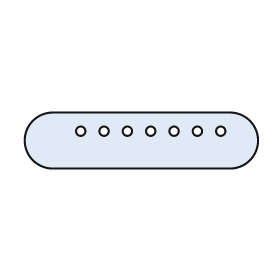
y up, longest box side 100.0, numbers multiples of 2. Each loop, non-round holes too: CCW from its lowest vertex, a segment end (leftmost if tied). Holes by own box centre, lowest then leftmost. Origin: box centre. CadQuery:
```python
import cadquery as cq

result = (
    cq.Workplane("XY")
    .moveTo(-38.0, -12.0)
    .lineTo(38.0, -12.0)
    .threePointArc((50.0, 0.0), (38.0, 12.0))
    .lineTo(-38.0, 12.0)
    .threePointArc((-50.0, 0.0), (-38.0, -12.0))
    .close()
    .moveTo(-26.0, 4.0)
    .circle(2.0)
    .moveTo(-16.0, 4.0)
    .circle(2.0)
    .moveTo(-6.0, 4.0)
    .circle(2.0)
    .moveTo(4.0, 4.0)
    .circle(2.0)
    .moveTo(14.0, 4.0)
    .circle(2.0)
    .moveTo(24.0, 4.0)
    .circle(2.0)
    .moveTo(34.0, 4.0)
    .circle(2.0)
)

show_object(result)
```